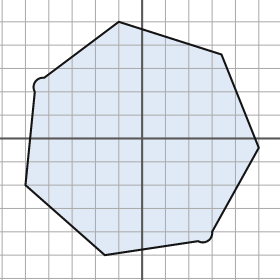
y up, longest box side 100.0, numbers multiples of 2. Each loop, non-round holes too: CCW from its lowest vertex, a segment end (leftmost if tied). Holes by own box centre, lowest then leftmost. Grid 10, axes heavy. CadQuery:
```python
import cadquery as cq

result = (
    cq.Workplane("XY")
    .moveTo(-16.0, -50.0)
    .lineTo(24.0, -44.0)
    .threePointArc((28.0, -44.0), (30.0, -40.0))
    .lineTo(50.0, -4.0)
    .lineTo(34.0, 36.0)
    .lineTo(-10.0, 50.0)
    .lineTo(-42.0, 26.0)
    .threePointArc((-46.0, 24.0), (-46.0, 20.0))
    .lineTo(-50.0, -20.0)
    .close()
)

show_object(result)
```